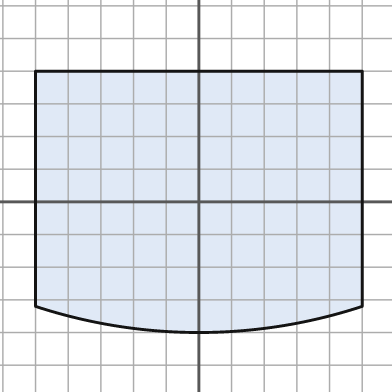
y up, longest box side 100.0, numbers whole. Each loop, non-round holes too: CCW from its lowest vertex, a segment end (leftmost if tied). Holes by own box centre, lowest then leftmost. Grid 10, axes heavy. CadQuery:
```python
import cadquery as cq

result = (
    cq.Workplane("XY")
    .moveTo(-50.0, -32.0)
    .threePointArc((0.0, -40.0), (50.0, -32.0))
    .lineTo(50.0, 40.0)
    .lineTo(-50.0, 40.0)
    .close()
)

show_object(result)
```